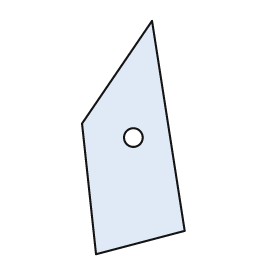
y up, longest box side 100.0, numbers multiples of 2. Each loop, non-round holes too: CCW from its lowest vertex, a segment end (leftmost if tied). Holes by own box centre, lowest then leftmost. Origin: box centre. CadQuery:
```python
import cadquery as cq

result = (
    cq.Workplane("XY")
    .moveTo(-16.0, -50.0)
    .lineTo(22.0, -40.0)
    .lineTo(8.0, 50.0)
    .lineTo(-22.0, 6.0)
    .close()
    .moveTo(0.0, 0.0)
    .circle(4.0)
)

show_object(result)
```